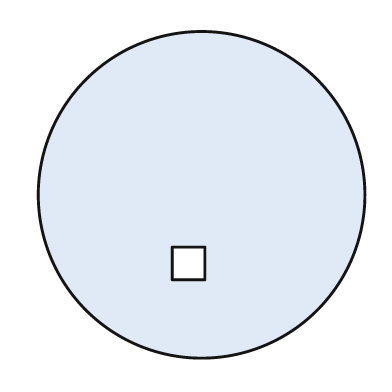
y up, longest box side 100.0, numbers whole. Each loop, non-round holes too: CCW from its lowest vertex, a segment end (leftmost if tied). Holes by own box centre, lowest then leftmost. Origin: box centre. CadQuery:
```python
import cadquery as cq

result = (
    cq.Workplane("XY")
    .moveTo(0.0, 0.0)
    .circle(50.0)
    .moveTo(-9.0, -26.0)
    .lineTo(1.0, -26.0)
    .lineTo(1.0, -16.0)
    .lineTo(-9.0, -16.0)
    .close()
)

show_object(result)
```